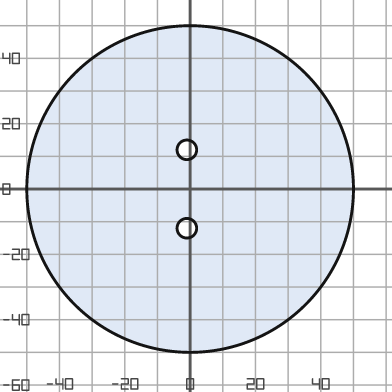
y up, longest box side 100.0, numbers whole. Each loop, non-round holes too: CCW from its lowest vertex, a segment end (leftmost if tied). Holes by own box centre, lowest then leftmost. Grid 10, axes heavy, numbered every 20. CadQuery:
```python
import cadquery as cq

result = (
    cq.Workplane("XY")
    .moveTo(0.0, 0.0)
    .circle(50.0)
    .moveTo(-1.0, -12.0)
    .circle(3.0)
    .moveTo(-1.0, 12.0)
    .circle(3.0)
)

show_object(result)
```